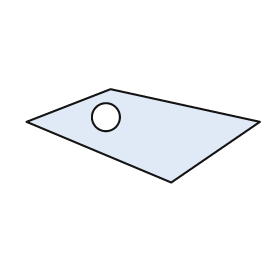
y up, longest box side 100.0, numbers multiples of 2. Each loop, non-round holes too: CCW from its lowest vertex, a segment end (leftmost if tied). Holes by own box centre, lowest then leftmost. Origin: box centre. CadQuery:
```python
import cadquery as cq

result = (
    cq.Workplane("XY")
    .moveTo(12.0, -20.0)
    .lineTo(50.0, 6.0)
    .lineTo(-14.0, 20.0)
    .lineTo(-50.0, 6.0)
    .close()
    .moveTo(-16.0, 8.0)
    .circle(6.0)
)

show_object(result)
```